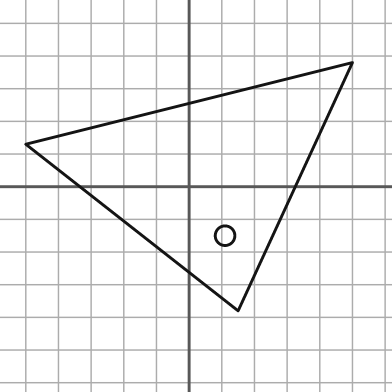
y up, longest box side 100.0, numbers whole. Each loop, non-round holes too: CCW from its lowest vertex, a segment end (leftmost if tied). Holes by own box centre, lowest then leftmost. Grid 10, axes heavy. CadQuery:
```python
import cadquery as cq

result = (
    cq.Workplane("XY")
    .moveTo(15.0, -38.0)
    .lineTo(50.0, 38.0)
    .lineTo(-50.0, 13.0)
    .close()
    .moveTo(11.0, -15.0)
    .circle(3.0)
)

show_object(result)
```